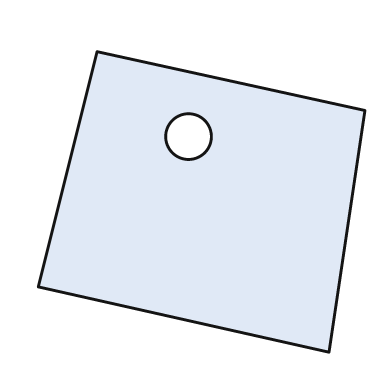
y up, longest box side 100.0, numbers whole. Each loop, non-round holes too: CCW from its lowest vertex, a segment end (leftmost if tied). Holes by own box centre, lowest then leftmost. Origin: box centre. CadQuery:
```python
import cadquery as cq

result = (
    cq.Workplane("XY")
    .moveTo(39.0, -46.0)
    .lineTo(50.0, 28.0)
    .lineTo(-32.0, 46.0)
    .lineTo(-50.0, -26.0)
    .close()
    .moveTo(-4.0, 20.0)
    .circle(7.0)
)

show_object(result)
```